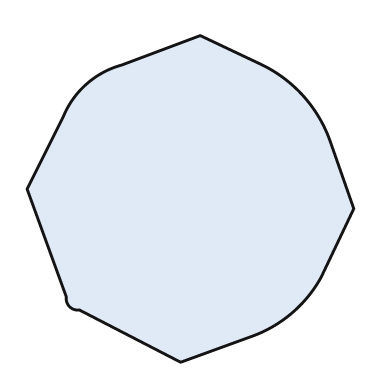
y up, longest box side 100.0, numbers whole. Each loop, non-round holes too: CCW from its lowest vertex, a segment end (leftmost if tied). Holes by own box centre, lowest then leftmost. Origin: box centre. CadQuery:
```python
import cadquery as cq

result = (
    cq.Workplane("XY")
    .moveTo(-3.0, -50.0)
    .lineTo(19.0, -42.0)
    .threePointArc((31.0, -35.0), (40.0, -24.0))
    .lineTo(50.0, -3.0)
    .lineTo(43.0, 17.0)
    .threePointArc((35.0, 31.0), (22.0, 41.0))
    .lineTo(3.0, 50.0)
    .lineTo(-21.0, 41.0)
    .threePointArc((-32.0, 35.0), (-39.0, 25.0))
    .lineTo(-50.0, 3.0)
    .lineTo(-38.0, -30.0)
    .threePointArc((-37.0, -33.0), (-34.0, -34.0))
    .close()
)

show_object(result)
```